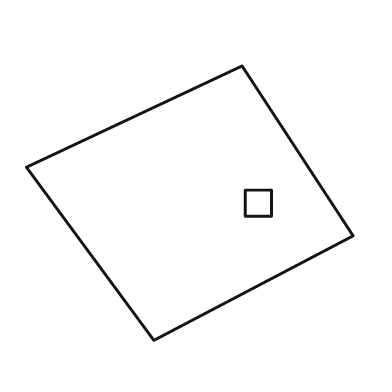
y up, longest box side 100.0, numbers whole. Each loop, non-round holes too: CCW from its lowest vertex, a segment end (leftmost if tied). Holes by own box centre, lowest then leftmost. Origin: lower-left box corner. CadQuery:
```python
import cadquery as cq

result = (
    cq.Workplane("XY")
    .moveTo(39.0, 0.0)
    .lineTo(100.0, 32.0)
    .lineTo(66.0, 84.0)
    .lineTo(0.0, 53.0)
    .close()
    .moveTo(67.0, 38.0)
    .lineTo(75.0, 38.0)
    .lineTo(75.0, 46.0)
    .lineTo(67.0, 46.0)
    .close()
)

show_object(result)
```